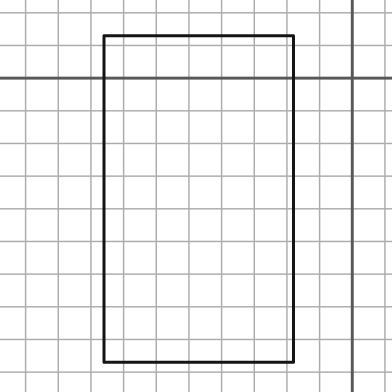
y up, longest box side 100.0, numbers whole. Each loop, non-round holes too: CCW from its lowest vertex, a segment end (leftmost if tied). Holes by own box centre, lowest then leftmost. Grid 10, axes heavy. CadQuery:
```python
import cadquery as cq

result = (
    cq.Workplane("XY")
    .moveTo(-76.0, -87.0)
    .lineTo(-18.0, -87.0)
    .lineTo(-18.0, 13.0)
    .lineTo(-76.0, 13.0)
    .close()
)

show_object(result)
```